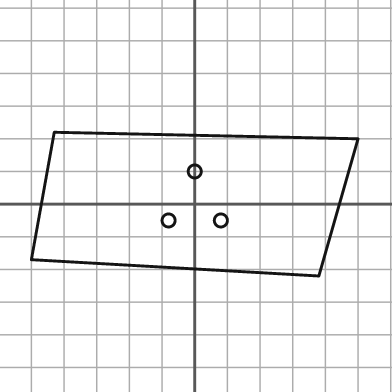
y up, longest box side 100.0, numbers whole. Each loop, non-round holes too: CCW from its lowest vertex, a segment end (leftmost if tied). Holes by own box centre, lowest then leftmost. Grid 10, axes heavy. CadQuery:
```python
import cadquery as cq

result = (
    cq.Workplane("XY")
    .moveTo(38.0, -22.0)
    .lineTo(50.0, 20.0)
    .lineTo(-43.0, 22.0)
    .lineTo(-50.0, -17.0)
    .close()
    .moveTo(-8.0, -5.0)
    .circle(2.0)
    .moveTo(8.0, -5.0)
    .circle(2.0)
    .moveTo(0.0, 10.0)
    .circle(2.0)
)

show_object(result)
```